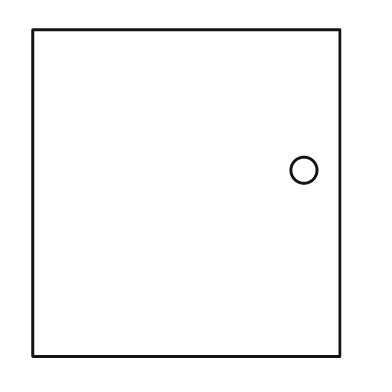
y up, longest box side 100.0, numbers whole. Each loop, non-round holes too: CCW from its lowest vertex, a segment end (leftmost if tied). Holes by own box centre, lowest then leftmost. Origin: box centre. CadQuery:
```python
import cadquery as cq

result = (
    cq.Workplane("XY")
    .moveTo(-47.0, -50.0)
    .lineTo(47.0, -50.0)
    .lineTo(47.0, 50.0)
    .lineTo(-47.0, 50.0)
    .close()
    .moveTo(36.0, 7.0)
    .circle(4.0)
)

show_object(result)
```